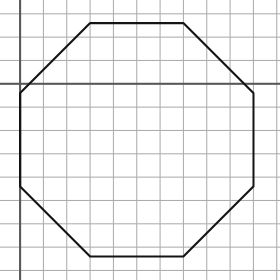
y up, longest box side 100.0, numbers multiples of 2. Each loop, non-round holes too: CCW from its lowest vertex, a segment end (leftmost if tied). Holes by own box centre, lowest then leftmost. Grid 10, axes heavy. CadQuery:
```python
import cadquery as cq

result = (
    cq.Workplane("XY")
    .moveTo(30.0, -74.0)
    .lineTo(70.0, -74.0)
    .lineTo(100.0, -44.0)
    .lineTo(100.0, -4.0)
    .lineTo(70.0, 26.0)
    .lineTo(30.0, 26.0)
    .lineTo(0.0, -4.0)
    .lineTo(0.0, -44.0)
    .close()
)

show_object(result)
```